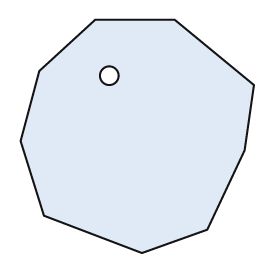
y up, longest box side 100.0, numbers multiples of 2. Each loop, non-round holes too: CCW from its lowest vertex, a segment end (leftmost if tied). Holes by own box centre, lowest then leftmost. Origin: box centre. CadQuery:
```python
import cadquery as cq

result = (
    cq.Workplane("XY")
    .moveTo(2.0, -50.0)
    .lineTo(30.0, -40.0)
    .lineTo(46.0, -6.0)
    .lineTo(50.0, 22.0)
    .lineTo(16.0, 50.0)
    .lineTo(-18.0, 50.0)
    .lineTo(-42.0, 28.0)
    .lineTo(-50.0, -2.0)
    .lineTo(-40.0, -34.0)
    .close()
    .moveTo(-12.0, 26.0)
    .circle(4.0)
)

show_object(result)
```